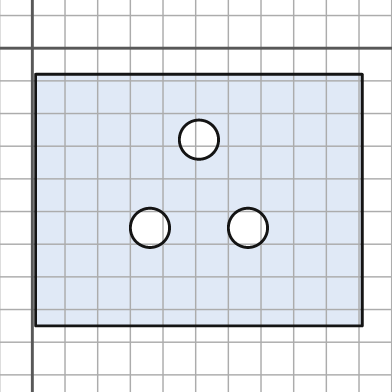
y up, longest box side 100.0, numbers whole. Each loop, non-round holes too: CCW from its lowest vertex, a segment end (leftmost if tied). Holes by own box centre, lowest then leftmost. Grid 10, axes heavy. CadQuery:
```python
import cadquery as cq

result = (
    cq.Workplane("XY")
    .moveTo(1.0, -85.0)
    .lineTo(101.0, -85.0)
    .lineTo(101.0, -8.0)
    .lineTo(1.0, -8.0)
    .close()
    .moveTo(36.0, -55.0)
    .circle(6.0)
    .moveTo(66.0, -55.0)
    .circle(6.0)
    .moveTo(51.0, -28.0)
    .circle(6.0)
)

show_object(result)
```